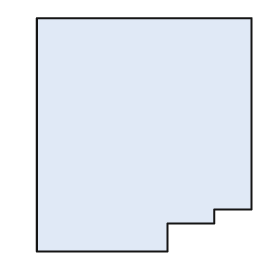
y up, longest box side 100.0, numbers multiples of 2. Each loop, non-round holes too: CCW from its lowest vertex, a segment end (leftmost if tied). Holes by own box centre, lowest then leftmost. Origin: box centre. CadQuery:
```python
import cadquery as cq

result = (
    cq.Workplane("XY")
    .moveTo(-46.0, -50.0)
    .lineTo(10.0, -50.0)
    .lineTo(10.0, -38.0)
    .lineTo(30.0, -38.0)
    .lineTo(30.0, -32.0)
    .lineTo(46.0, -32.0)
    .lineTo(46.0, 50.0)
    .lineTo(-46.0, 50.0)
    .close()
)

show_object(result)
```